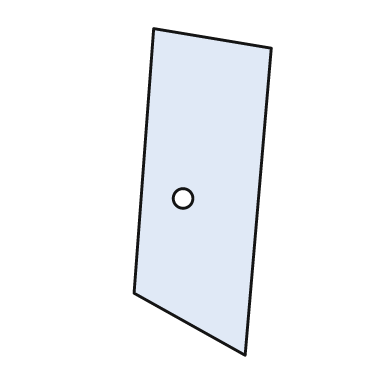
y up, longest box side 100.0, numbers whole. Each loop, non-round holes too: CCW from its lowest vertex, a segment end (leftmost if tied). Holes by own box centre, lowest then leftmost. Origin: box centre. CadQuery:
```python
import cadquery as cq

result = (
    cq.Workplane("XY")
    .moveTo(13.0, -50.0)
    .lineTo(21.0, 44.0)
    .lineTo(-15.0, 50.0)
    .lineTo(-21.0, -31.0)
    .close()
    .moveTo(-6.0, -2.0)
    .circle(3.0)
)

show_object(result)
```